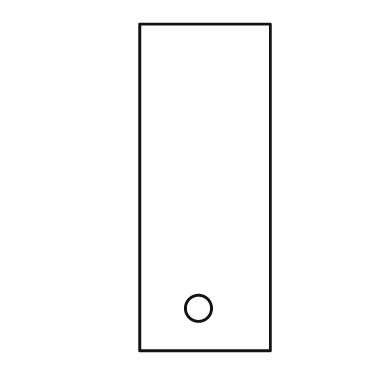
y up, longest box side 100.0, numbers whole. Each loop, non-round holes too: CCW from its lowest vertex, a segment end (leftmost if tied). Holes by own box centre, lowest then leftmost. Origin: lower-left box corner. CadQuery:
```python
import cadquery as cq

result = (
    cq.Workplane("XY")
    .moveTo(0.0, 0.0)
    .lineTo(40.0, 0.0)
    .lineTo(40.0, 100.0)
    .lineTo(0.0, 100.0)
    .close()
    .moveTo(18.0, 13.0)
    .circle(4.0)
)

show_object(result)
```